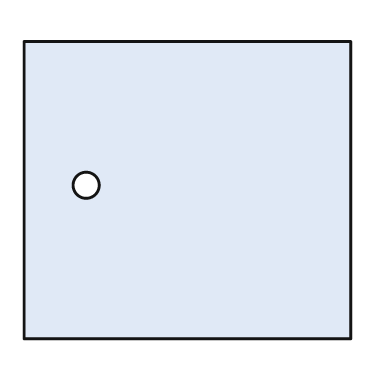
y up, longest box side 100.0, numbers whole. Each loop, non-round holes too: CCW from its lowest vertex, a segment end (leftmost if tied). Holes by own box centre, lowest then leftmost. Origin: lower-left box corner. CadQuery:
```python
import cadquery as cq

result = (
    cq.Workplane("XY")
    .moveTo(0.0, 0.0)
    .lineTo(100.0, 0.0)
    .lineTo(100.0, 91.0)
    .lineTo(0.0, 91.0)
    .close()
    .moveTo(19.0, 47.0)
    .circle(4.0)
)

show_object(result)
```